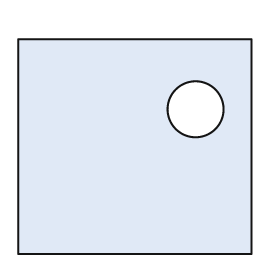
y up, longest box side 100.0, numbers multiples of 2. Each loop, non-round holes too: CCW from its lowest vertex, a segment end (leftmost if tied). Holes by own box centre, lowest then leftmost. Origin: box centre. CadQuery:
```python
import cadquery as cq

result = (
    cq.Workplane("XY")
    .moveTo(-50.0, -46.0)
    .lineTo(50.0, -46.0)
    .lineTo(50.0, 46.0)
    .lineTo(-50.0, 46.0)
    .close()
    .moveTo(26.0, 16.0)
    .circle(12.0)
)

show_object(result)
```